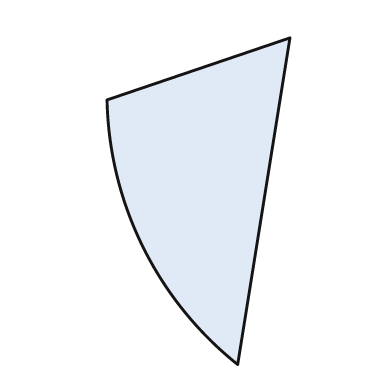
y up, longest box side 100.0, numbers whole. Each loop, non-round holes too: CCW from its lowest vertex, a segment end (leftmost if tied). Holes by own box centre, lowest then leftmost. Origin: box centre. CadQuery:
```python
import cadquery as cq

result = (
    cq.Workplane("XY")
    .moveTo(12.0, -50.0)
    .lineTo(28.0, 50.0)
    .lineTo(-28.0, 31.0)
    .threePointArc((-17.0, -14.0), (12.0, -50.0))
    .close()
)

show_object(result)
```